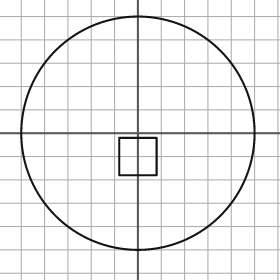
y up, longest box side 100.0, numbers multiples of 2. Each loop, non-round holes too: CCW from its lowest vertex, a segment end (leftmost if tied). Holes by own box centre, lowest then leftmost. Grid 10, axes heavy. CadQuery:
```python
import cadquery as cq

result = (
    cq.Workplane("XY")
    .moveTo(0.0, 0.0)
    .circle(50.0)
    .moveTo(-8.0, -18.0)
    .lineTo(8.0, -18.0)
    .lineTo(8.0, -2.0)
    .lineTo(-8.0, -2.0)
    .close()
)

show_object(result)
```